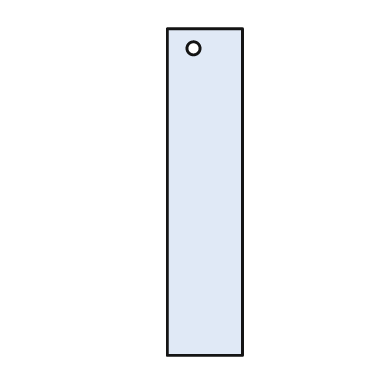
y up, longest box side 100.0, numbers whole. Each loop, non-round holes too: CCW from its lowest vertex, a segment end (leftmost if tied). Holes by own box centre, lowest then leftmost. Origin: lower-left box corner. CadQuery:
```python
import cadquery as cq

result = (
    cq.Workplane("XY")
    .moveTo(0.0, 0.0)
    .lineTo(23.0, 0.0)
    .lineTo(23.0, 100.0)
    .lineTo(0.0, 100.0)
    .close()
    .moveTo(8.0, 94.0)
    .circle(2.0)
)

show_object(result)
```